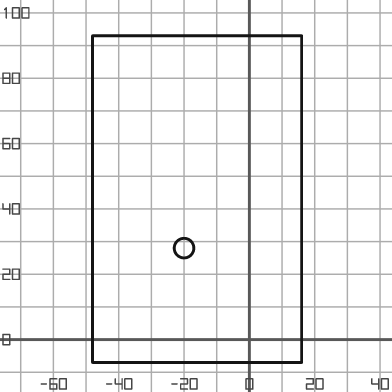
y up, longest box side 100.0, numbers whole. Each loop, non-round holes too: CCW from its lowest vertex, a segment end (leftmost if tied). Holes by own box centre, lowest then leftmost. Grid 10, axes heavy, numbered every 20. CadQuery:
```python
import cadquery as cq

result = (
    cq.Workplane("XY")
    .moveTo(-48.0, -7.0)
    .lineTo(16.0, -7.0)
    .lineTo(16.0, 93.0)
    .lineTo(-48.0, 93.0)
    .close()
    .moveTo(-20.0, 28.0)
    .circle(3.0)
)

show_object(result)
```